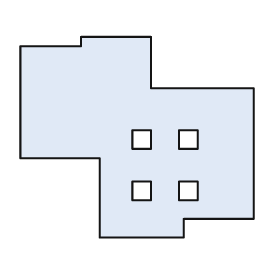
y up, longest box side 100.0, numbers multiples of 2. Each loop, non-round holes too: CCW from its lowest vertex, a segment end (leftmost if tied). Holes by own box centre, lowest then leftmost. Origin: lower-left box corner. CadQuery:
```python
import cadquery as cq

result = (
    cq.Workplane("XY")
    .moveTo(34.0, 0.0)
    .lineTo(70.0, 0.0)
    .lineTo(70.0, 8.0)
    .lineTo(100.0, 8.0)
    .lineTo(100.0, 64.0)
    .lineTo(56.0, 64.0)
    .lineTo(56.0, 86.0)
    .lineTo(26.0, 86.0)
    .lineTo(26.0, 82.0)
    .lineTo(0.0, 82.0)
    .lineTo(0.0, 34.0)
    .lineTo(34.0, 34.0)
    .close()
    .moveTo(48.0, 16.0)
    .lineTo(56.0, 16.0)
    .lineTo(56.0, 24.0)
    .lineTo(48.0, 24.0)
    .close()
    .moveTo(68.0, 16.0)
    .lineTo(76.0, 16.0)
    .lineTo(76.0, 24.0)
    .lineTo(68.0, 24.0)
    .close()
    .moveTo(48.0, 38.0)
    .lineTo(56.0, 38.0)
    .lineTo(56.0, 46.0)
    .lineTo(48.0, 46.0)
    .close()
    .moveTo(68.0, 38.0)
    .lineTo(76.0, 38.0)
    .lineTo(76.0, 46.0)
    .lineTo(68.0, 46.0)
    .close()
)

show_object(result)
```